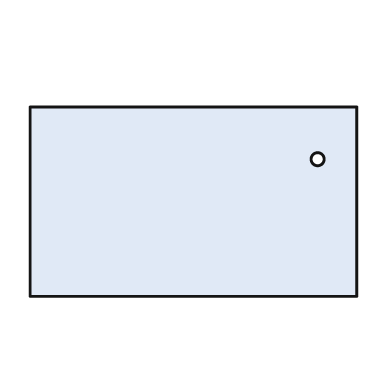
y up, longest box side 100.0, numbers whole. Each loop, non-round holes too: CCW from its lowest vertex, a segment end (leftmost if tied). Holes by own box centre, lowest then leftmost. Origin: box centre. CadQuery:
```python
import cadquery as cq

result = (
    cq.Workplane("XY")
    .moveTo(-50.0, -29.0)
    .lineTo(50.0, -29.0)
    .lineTo(50.0, 29.0)
    .lineTo(-50.0, 29.0)
    .close()
    .moveTo(38.0, 13.0)
    .circle(2.0)
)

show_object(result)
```